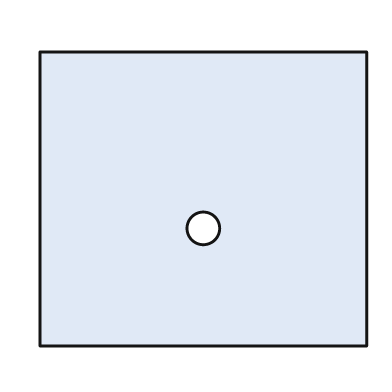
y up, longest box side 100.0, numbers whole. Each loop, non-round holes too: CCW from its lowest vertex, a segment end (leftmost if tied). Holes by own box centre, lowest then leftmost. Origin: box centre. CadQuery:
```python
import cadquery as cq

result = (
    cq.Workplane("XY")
    .moveTo(-50.0, -45.0)
    .lineTo(50.0, -45.0)
    .lineTo(50.0, 45.0)
    .lineTo(-50.0, 45.0)
    .close()
    .moveTo(0.0, -9.0)
    .circle(5.0)
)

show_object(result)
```